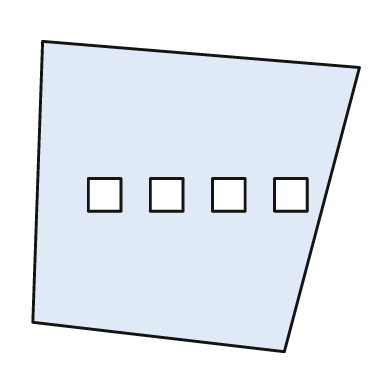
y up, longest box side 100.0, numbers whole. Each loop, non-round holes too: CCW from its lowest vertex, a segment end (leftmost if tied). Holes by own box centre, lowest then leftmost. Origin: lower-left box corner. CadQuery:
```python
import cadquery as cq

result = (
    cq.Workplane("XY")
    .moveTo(77.0, 0.0)
    .lineTo(100.0, 87.0)
    .lineTo(3.0, 95.0)
    .lineTo(0.0, 9.0)
    .close()
    .moveTo(17.0, 43.0)
    .lineTo(27.0, 43.0)
    .lineTo(27.0, 53.0)
    .lineTo(17.0, 53.0)
    .close()
    .moveTo(36.0, 43.0)
    .lineTo(46.0, 43.0)
    .lineTo(46.0, 53.0)
    .lineTo(36.0, 53.0)
    .close()
    .moveTo(55.0, 43.0)
    .lineTo(65.0, 43.0)
    .lineTo(65.0, 53.0)
    .lineTo(55.0, 53.0)
    .close()
    .moveTo(74.0, 43.0)
    .lineTo(84.0, 43.0)
    .lineTo(84.0, 53.0)
    .lineTo(74.0, 53.0)
    .close()
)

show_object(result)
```